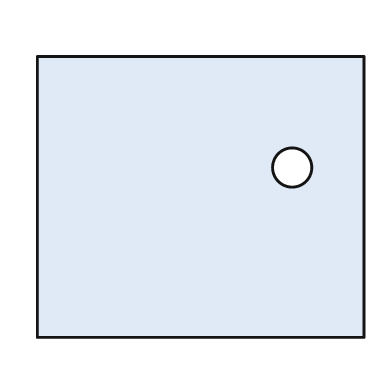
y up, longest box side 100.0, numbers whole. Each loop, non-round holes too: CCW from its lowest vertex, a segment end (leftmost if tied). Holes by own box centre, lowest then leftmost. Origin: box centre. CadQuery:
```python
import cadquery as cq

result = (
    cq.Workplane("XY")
    .moveTo(-50.0, -43.0)
    .lineTo(50.0, -43.0)
    .lineTo(50.0, 43.0)
    .lineTo(-50.0, 43.0)
    .close()
    .moveTo(28.0, 9.0)
    .circle(6.0)
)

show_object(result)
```